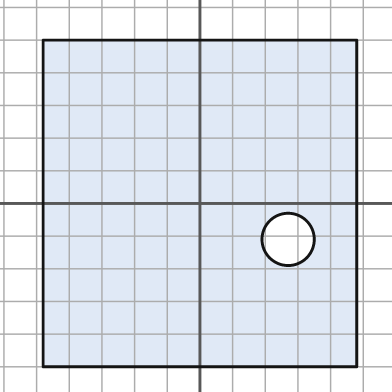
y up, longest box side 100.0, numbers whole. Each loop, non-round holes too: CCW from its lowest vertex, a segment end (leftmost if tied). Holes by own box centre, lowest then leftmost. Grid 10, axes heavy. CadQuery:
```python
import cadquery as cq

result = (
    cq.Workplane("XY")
    .moveTo(-48.0, -50.0)
    .lineTo(48.0, -50.0)
    .lineTo(48.0, 50.0)
    .lineTo(-48.0, 50.0)
    .close()
    .moveTo(27.0, -11.0)
    .circle(8.0)
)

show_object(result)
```